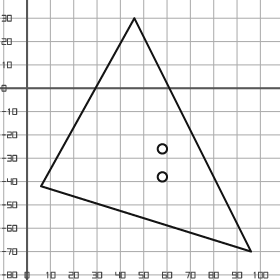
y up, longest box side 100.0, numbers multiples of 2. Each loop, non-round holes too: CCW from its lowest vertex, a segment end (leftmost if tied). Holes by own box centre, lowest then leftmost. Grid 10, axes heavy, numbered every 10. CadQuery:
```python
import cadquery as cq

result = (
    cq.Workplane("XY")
    .moveTo(96.0, -70.0)
    .lineTo(46.0, 30.0)
    .lineTo(6.0, -42.0)
    .close()
    .moveTo(58.0, -38.0)
    .circle(2.0)
    .moveTo(58.0, -26.0)
    .circle(2.0)
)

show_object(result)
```